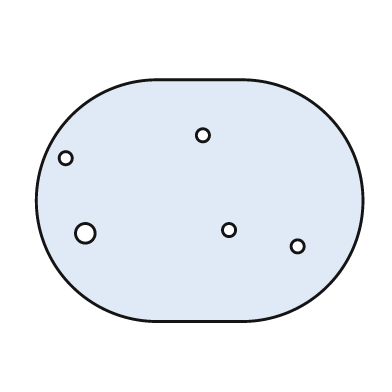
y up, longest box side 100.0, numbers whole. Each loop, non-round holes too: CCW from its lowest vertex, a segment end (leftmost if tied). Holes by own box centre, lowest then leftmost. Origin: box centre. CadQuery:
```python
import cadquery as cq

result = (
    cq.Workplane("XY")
    .moveTo(-13.0, -37.0)
    .lineTo(13.0, -37.0)
    .threePointArc((50.0, 0.0), (13.0, 37.0))
    .lineTo(-13.0, 37.0)
    .threePointArc((-50.0, 0.0), (-13.0, -37.0))
    .close()
    .moveTo(30.0, -14.0)
    .circle(2.0)
    .moveTo(-35.0, -10.0)
    .circle(3.0)
    .moveTo(9.0, -9.0)
    .circle(2.0)
    .moveTo(-41.0, 13.0)
    .circle(2.0)
    .moveTo(1.0, 20.0)
    .circle(2.0)
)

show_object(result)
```